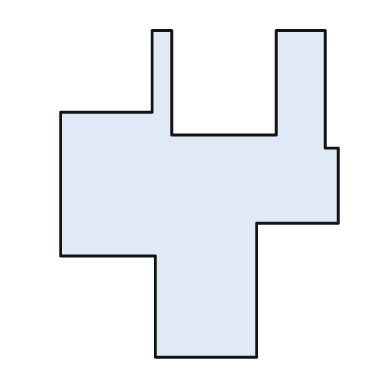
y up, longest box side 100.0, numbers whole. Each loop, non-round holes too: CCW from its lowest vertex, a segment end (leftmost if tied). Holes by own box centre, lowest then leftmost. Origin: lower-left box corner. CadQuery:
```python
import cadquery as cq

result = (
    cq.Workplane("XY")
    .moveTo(29.0, 0.0)
    .lineTo(60.0, 0.0)
    .lineTo(60.0, 41.0)
    .lineTo(85.0, 41.0)
    .lineTo(85.0, 64.0)
    .lineTo(81.0, 64.0)
    .lineTo(81.0, 100.0)
    .lineTo(66.0, 100.0)
    .lineTo(66.0, 68.0)
    .lineTo(34.0, 68.0)
    .lineTo(34.0, 100.0)
    .lineTo(28.0, 100.0)
    .lineTo(28.0, 75.0)
    .lineTo(0.0, 75.0)
    .lineTo(0.0, 31.0)
    .lineTo(29.0, 31.0)
    .close()
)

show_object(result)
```